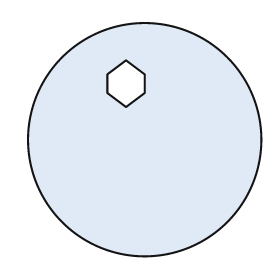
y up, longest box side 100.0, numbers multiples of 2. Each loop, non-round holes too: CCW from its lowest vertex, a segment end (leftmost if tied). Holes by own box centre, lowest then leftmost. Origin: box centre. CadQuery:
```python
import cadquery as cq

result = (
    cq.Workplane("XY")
    .moveTo(0.0, 0.0)
    .circle(50.0)
    .moveTo(-8.0, 14.0)
    .lineTo(0.0, 20.0)
    .lineTo(0.0, 28.0)
    .lineTo(-8.0, 34.0)
    .lineTo(-16.0, 28.0)
    .lineTo(-16.0, 20.0)
    .close()
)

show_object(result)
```